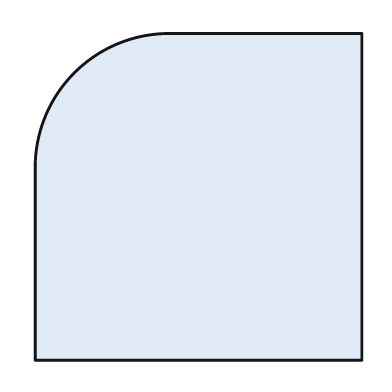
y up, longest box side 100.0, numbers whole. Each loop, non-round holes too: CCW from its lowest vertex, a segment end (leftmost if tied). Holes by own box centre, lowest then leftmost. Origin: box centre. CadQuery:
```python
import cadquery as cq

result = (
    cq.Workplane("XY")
    .moveTo(-50.0, -50.0)
    .lineTo(50.0, -50.0)
    .lineTo(50.0, 50.0)
    .lineTo(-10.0, 50.0)
    .threePointArc((-38.0, 38.0), (-50.0, 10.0))
    .close()
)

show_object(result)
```